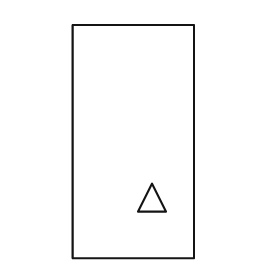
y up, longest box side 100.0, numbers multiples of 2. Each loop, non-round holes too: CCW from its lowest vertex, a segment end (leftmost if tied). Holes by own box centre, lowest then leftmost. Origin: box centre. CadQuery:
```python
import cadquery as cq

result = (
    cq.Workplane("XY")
    .moveTo(-26.0, -50.0)
    .lineTo(26.0, -50.0)
    .lineTo(26.0, 50.0)
    .lineTo(-26.0, 50.0)
    .close()
    .moveTo(2.0, -30.0)
    .lineTo(14.0, -30.0)
    .lineTo(8.0, -18.0)
    .close()
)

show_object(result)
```